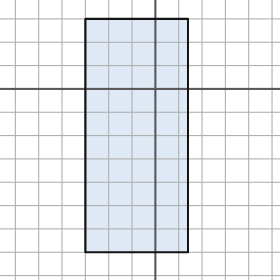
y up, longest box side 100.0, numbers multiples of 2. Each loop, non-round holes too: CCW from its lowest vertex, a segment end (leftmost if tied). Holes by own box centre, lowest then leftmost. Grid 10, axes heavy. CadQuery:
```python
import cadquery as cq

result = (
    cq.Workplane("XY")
    .moveTo(-30.0, -70.0)
    .lineTo(14.0, -70.0)
    .lineTo(14.0, 30.0)
    .lineTo(-30.0, 30.0)
    .close()
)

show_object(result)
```